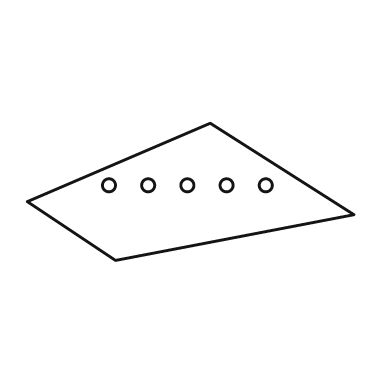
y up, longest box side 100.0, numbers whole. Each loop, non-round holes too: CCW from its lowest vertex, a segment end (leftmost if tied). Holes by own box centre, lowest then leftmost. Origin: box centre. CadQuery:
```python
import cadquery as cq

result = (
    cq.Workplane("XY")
    .moveTo(-23.0, -21.0)
    .lineTo(50.0, -7.0)
    .lineTo(6.0, 21.0)
    .lineTo(-50.0, -3.0)
    .close()
    .moveTo(-25.0, 2.0)
    .circle(2.0)
    .moveTo(-13.0, 2.0)
    .circle(2.0)
    .moveTo(-1.0, 2.0)
    .circle(2.0)
    .moveTo(11.0, 2.0)
    .circle(2.0)
    .moveTo(23.0, 2.0)
    .circle(2.0)
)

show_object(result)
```